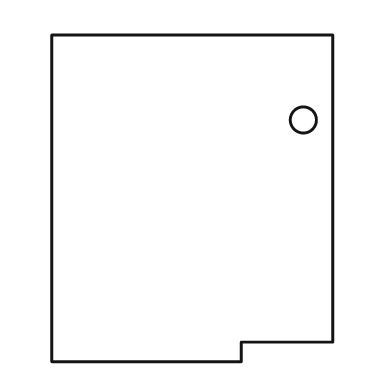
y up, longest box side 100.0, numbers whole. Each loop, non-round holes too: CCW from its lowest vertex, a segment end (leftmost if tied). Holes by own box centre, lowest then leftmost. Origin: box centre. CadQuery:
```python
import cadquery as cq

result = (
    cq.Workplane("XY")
    .moveTo(-43.0, -50.0)
    .lineTo(15.0, -50.0)
    .lineTo(15.0, -44.0)
    .lineTo(43.0, -44.0)
    .lineTo(43.0, 50.0)
    .lineTo(-43.0, 50.0)
    .close()
    .moveTo(34.0, 24.0)
    .circle(4.0)
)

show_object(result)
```